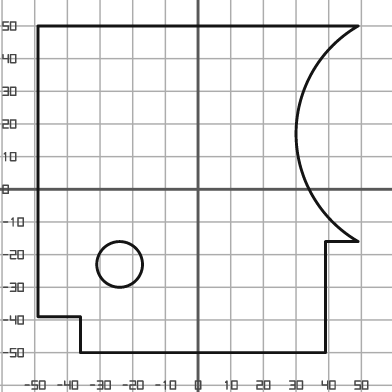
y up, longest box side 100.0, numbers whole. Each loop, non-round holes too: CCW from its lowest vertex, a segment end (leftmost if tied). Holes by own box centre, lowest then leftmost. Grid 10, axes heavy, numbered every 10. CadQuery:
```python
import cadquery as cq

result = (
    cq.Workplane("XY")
    .moveTo(-36.0, -50.0)
    .lineTo(39.0, -50.0)
    .lineTo(39.0, -16.0)
    .lineTo(49.0, -16.0)
    .threePointArc((30.0, 17.0), (49.0, 50.0))
    .lineTo(-49.0, 50.0)
    .lineTo(-49.0, -39.0)
    .lineTo(-36.0, -39.0)
    .close()
    .moveTo(-24.0, -23.0)
    .circle(7.0)
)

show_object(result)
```